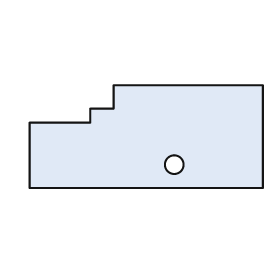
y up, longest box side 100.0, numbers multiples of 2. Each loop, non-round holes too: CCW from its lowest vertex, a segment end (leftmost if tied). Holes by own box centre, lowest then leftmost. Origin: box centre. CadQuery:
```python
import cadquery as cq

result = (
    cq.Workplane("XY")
    .moveTo(-50.0, -22.0)
    .lineTo(50.0, -22.0)
    .lineTo(50.0, 22.0)
    .lineTo(-14.0, 22.0)
    .lineTo(-14.0, 12.0)
    .lineTo(-24.0, 12.0)
    .lineTo(-24.0, 6.0)
    .lineTo(-50.0, 6.0)
    .close()
    .moveTo(12.0, -12.0)
    .circle(4.0)
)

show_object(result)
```